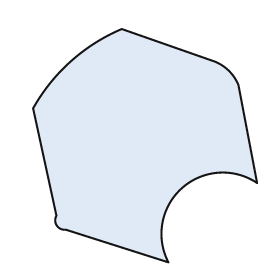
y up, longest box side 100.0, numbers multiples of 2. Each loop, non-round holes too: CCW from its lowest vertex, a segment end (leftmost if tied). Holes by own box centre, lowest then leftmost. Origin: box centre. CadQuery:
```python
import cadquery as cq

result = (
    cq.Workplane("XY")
    .moveTo(10.0, -50.0)
    .threePointArc((16.0, -18.0), (48.0, -16.0))
    .lineTo(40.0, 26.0)
    .threePointArc((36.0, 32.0), (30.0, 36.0))
    .lineTo(-10.0, 50.0)
    .threePointArc((-32.0, 36.0), (-48.0, 16.0))
    .lineTo(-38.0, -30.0)
    .threePointArc((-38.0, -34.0), (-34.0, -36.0))
    .close()
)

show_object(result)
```